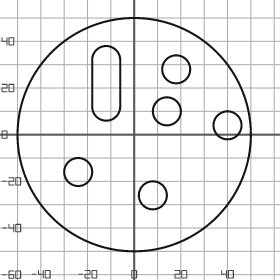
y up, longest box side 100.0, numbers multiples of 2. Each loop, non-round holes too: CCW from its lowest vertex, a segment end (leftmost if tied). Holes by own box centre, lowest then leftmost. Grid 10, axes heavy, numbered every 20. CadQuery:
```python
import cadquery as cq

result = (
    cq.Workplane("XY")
    .moveTo(0.0, 0.0)
    .circle(50.0)
    .moveTo(8.0, -26.0)
    .circle(6.0)
    .moveTo(-24.0, -16.0)
    .circle(6.0)
    .moveTo(40.0, 4.0)
    .circle(6.0)
    .moveTo(14.0, 10.0)
    .circle(6.0)
    .moveTo(-18.0, 12.0)
    .threePointArc((-12.0, 6.0), (-6.0, 12.0))
    .lineTo(-6.0, 32.0)
    .threePointArc((-12.0, 38.0), (-18.0, 32.0))
    .close()
    .moveTo(18.0, 28.0)
    .circle(6.0)
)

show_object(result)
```